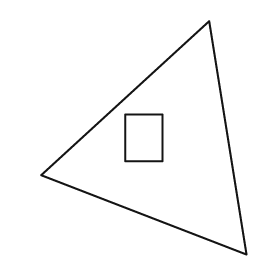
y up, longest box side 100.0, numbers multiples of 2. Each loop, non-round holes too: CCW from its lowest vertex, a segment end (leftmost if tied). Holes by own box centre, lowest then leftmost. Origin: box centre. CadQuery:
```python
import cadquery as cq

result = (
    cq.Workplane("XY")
    .moveTo(44.0, -50.0)
    .lineTo(28.0, 50.0)
    .lineTo(-44.0, -16.0)
    .close()
    .moveTo(-8.0, -10.0)
    .lineTo(8.0, -10.0)
    .lineTo(8.0, 10.0)
    .lineTo(-8.0, 10.0)
    .close()
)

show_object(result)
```